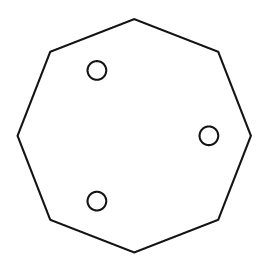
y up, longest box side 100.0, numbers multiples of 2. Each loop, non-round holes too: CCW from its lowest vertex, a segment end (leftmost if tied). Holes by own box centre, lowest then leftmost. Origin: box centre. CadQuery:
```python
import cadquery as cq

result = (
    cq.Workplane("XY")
    .moveTo(0.0, -50.0)
    .lineTo(36.0, -36.0)
    .lineTo(50.0, 0.0)
    .lineTo(36.0, 36.0)
    .lineTo(0.0, 50.0)
    .lineTo(-36.0, 36.0)
    .lineTo(-50.0, 0.0)
    .lineTo(-36.0, -36.0)
    .close()
    .moveTo(-16.0, -28.0)
    .circle(4.0)
    .moveTo(32.0, 0.0)
    .circle(4.0)
    .moveTo(-16.0, 28.0)
    .circle(4.0)
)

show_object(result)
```